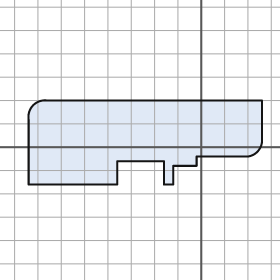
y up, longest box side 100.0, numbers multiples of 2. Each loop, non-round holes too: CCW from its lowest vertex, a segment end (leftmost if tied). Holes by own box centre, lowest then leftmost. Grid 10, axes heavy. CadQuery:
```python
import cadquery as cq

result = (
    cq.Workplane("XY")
    .moveTo(-74.0, -16.0)
    .lineTo(-36.0, -16.0)
    .lineTo(-36.0, -6.0)
    .lineTo(-16.0, -6.0)
    .lineTo(-16.0, -16.0)
    .lineTo(-12.0, -16.0)
    .lineTo(-12.0, -8.0)
    .lineTo(-2.0, -8.0)
    .lineTo(-2.0, -4.0)
    .lineTo(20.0, -4.0)
    .threePointArc((24.0, -2.0), (26.0, 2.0))
    .lineTo(26.0, 20.0)
    .lineTo(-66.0, 20.0)
    .threePointArc((-72.0, 18.0), (-74.0, 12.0))
    .close()
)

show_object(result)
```